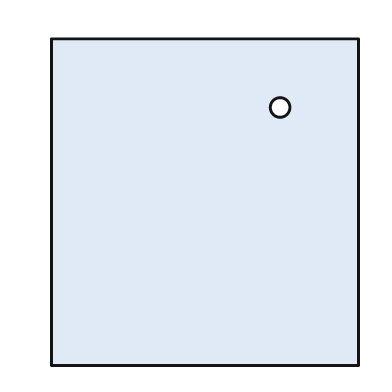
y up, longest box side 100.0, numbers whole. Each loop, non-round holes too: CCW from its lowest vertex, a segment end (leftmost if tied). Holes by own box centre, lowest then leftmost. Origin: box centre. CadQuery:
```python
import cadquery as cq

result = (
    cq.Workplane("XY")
    .moveTo(-47.0, -50.0)
    .lineTo(47.0, -50.0)
    .lineTo(47.0, 50.0)
    .lineTo(-47.0, 50.0)
    .close()
    .moveTo(23.0, 29.0)
    .circle(3.0)
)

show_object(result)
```